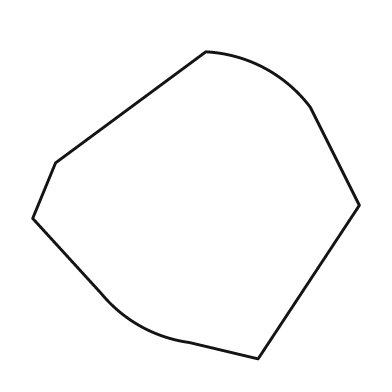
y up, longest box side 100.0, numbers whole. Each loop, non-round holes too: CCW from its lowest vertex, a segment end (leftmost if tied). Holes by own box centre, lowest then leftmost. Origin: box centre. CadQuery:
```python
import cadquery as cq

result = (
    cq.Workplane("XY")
    .moveTo(19.0, -47.0)
    .lineTo(50.0, 0.0)
    .lineTo(35.0, 30.0)
    .threePointArc((21.0, 42.0), (3.0, 47.0))
    .lineTo(-43.0, 13.0)
    .lineTo(-50.0, -4.0)
    .lineTo(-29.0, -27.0)
    .threePointArc((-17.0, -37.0), (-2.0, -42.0))
    .close()
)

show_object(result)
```